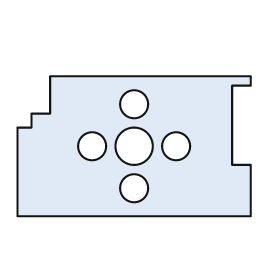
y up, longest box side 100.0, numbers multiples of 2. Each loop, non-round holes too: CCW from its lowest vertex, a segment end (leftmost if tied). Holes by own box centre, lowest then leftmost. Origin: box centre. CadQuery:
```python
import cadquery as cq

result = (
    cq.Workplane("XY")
    .moveTo(-50.0, -30.0)
    .lineTo(50.0, -30.0)
    .lineTo(50.0, -8.0)
    .lineTo(42.0, -8.0)
    .lineTo(42.0, 26.0)
    .lineTo(50.0, 26.0)
    .lineTo(50.0, 30.0)
    .lineTo(-36.0, 30.0)
    .lineTo(-36.0, 14.0)
    .lineTo(-44.0, 14.0)
    .lineTo(-44.0, 8.0)
    .lineTo(-50.0, 8.0)
    .close()
    .moveTo(0.0, -18.0)
    .circle(6.0)
    .moveTo(-18.0, 0.0)
    .circle(6.0)
    .moveTo(0.0, 0.0)
    .circle(8.0)
    .moveTo(18.0, 0.0)
    .circle(6.0)
    .moveTo(0.0, 18.0)
    .circle(6.0)
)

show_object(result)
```